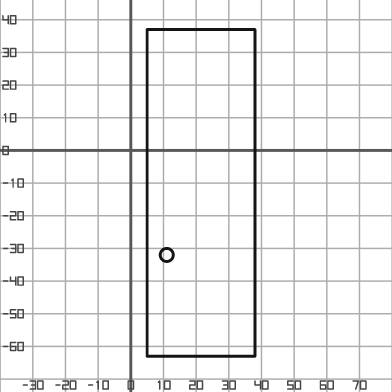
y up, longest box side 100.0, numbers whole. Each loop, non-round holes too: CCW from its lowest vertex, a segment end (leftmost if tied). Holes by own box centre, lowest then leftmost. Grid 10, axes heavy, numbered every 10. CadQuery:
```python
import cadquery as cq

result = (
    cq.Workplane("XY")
    .moveTo(5.0, -63.0)
    .lineTo(38.0, -63.0)
    .lineTo(38.0, 37.0)
    .lineTo(5.0, 37.0)
    .close()
    .moveTo(11.0, -32.0)
    .circle(2.0)
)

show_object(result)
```